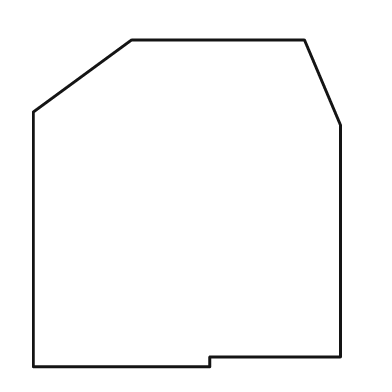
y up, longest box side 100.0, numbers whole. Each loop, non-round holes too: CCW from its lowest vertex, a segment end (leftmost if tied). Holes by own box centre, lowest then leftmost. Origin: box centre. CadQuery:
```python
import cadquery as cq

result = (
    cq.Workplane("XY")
    .moveTo(-47.0, -50.0)
    .lineTo(7.0, -50.0)
    .lineTo(7.0, -47.0)
    .lineTo(47.0, -47.0)
    .lineTo(47.0, 24.0)
    .lineTo(36.0, 50.0)
    .lineTo(-17.0, 50.0)
    .lineTo(-47.0, 28.0)
    .close()
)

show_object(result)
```